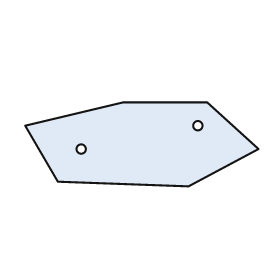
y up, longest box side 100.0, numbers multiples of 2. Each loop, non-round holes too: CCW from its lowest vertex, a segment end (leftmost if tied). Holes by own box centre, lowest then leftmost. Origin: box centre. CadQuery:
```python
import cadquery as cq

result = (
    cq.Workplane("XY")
    .moveTo(20.0, -18.0)
    .lineTo(50.0, -2.0)
    .lineTo(28.0, 18.0)
    .lineTo(-8.0, 18.0)
    .lineTo(-50.0, 8.0)
    .lineTo(-36.0, -16.0)
    .close()
    .moveTo(-26.0, -2.0)
    .circle(2.0)
    .moveTo(24.0, 8.0)
    .circle(2.0)
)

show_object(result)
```